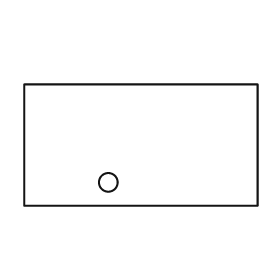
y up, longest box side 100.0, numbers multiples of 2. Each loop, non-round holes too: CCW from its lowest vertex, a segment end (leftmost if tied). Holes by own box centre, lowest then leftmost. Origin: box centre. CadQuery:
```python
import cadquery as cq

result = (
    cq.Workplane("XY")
    .moveTo(-50.0, -26.0)
    .lineTo(50.0, -26.0)
    .lineTo(50.0, 26.0)
    .lineTo(-50.0, 26.0)
    .close()
    .moveTo(-14.0, -16.0)
    .circle(4.0)
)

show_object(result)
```